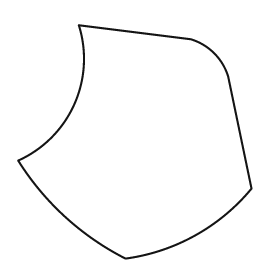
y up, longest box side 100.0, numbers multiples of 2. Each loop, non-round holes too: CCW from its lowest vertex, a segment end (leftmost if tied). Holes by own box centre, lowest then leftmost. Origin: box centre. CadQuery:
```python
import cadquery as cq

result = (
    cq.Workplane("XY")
    .moveTo(-4.0, -50.0)
    .threePointArc((26.0, -40.0), (50.0, -20.0))
    .lineTo(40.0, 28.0)
    .threePointArc((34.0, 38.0), (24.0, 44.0))
    .lineTo(-24.0, 50.0)
    .threePointArc((-26.0, 16.0), (-50.0, -8.0))
    .threePointArc((-30.0, -32.0), (-4.0, -50.0))
    .close()
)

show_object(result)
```